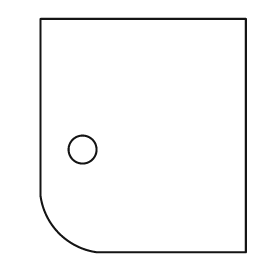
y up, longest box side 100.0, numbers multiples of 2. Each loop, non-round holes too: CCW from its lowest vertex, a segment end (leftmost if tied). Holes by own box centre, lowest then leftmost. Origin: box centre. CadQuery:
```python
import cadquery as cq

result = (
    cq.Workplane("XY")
    .moveTo(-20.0, -50.0)
    .lineTo(44.0, -50.0)
    .lineTo(44.0, 50.0)
    .lineTo(-44.0, 50.0)
    .lineTo(-44.0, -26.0)
    .threePointArc((-36.0, -42.0), (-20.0, -50.0))
    .close()
    .moveTo(-26.0, -6.0)
    .circle(6.0)
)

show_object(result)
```